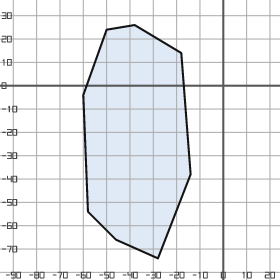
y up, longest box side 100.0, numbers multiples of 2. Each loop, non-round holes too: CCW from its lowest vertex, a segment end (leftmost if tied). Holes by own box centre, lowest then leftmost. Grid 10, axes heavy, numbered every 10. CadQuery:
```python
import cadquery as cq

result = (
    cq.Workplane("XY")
    .moveTo(-28.0, -74.0)
    .lineTo(-14.0, -38.0)
    .lineTo(-18.0, 14.0)
    .lineTo(-38.0, 26.0)
    .lineTo(-50.0, 24.0)
    .lineTo(-60.0, -4.0)
    .lineTo(-58.0, -54.0)
    .lineTo(-46.0, -66.0)
    .close()
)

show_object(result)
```